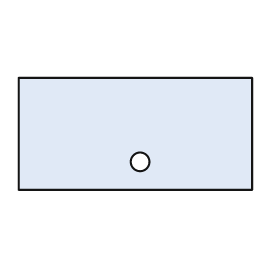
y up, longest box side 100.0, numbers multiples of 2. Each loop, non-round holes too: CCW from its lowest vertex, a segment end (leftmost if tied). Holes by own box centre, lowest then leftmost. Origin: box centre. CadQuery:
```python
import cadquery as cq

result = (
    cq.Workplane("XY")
    .moveTo(-50.0, -24.0)
    .lineTo(50.0, -24.0)
    .lineTo(50.0, 24.0)
    .lineTo(-50.0, 24.0)
    .close()
    .moveTo(2.0, -12.0)
    .circle(4.0)
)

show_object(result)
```